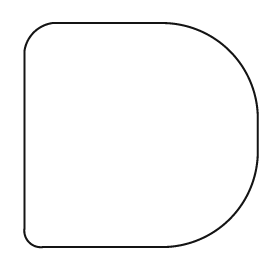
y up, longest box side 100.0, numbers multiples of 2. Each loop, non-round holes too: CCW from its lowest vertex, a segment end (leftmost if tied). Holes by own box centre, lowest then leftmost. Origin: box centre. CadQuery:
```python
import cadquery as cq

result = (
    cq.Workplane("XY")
    .moveTo(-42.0, -48.0)
    .lineTo(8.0, -48.0)
    .threePointArc((38.0, -36.0), (50.0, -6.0))
    .lineTo(50.0, 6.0)
    .threePointArc((38.0, 36.0), (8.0, 48.0))
    .lineTo(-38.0, 48.0)
    .threePointArc((-46.0, 44.0), (-50.0, 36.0))
    .lineTo(-50.0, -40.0)
    .threePointArc((-48.0, -46.0), (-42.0, -48.0))
    .close()
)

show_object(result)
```